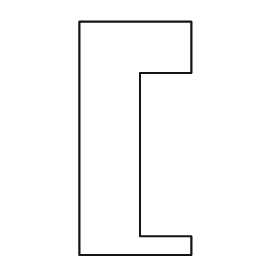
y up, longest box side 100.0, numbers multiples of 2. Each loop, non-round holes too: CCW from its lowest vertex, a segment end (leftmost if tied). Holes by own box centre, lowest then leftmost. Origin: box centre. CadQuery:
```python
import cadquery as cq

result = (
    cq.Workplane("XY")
    .moveTo(-24.0, -50.0)
    .lineTo(24.0, -50.0)
    .lineTo(24.0, -42.0)
    .lineTo(2.0, -42.0)
    .lineTo(2.0, 28.0)
    .lineTo(24.0, 28.0)
    .lineTo(24.0, 50.0)
    .lineTo(-24.0, 50.0)
    .close()
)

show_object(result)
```